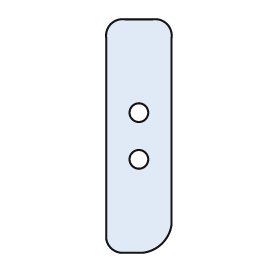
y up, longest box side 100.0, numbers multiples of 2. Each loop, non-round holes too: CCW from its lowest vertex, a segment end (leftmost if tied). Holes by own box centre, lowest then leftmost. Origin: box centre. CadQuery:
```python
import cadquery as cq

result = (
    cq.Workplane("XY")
    .moveTo(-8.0, -50.0)
    .lineTo(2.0, -50.0)
    .threePointArc((10.0, -46.0), (14.0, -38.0))
    .lineTo(14.0, 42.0)
    .threePointArc((12.0, 48.0), (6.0, 50.0))
    .lineTo(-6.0, 50.0)
    .threePointArc((-12.0, 48.0), (-14.0, 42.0))
    .lineTo(-14.0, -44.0)
    .threePointArc((-12.0, -48.0), (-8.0, -50.0))
    .close()
    .moveTo(0.0, -10.0)
    .circle(4.0)
    .moveTo(0.0, 10.0)
    .circle(4.0)
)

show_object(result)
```